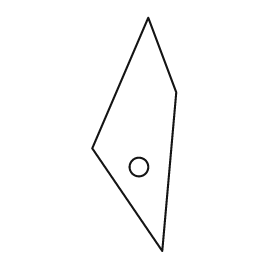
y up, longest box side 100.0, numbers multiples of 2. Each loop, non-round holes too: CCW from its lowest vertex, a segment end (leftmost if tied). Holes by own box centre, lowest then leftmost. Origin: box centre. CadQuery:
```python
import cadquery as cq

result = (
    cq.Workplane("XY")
    .moveTo(12.0, -50.0)
    .lineTo(18.0, 18.0)
    .lineTo(6.0, 50.0)
    .lineTo(-18.0, -6.0)
    .close()
    .moveTo(2.0, -14.0)
    .circle(4.0)
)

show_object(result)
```